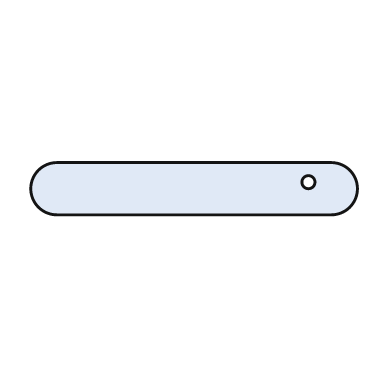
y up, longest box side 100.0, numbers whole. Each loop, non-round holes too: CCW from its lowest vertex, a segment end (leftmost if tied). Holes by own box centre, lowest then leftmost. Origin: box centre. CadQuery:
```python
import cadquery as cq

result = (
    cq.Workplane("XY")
    .moveTo(-42.0, -8.0)
    .lineTo(42.0, -8.0)
    .threePointArc((50.0, 0.0), (42.0, 8.0))
    .lineTo(-42.0, 8.0)
    .threePointArc((-50.0, 0.0), (-42.0, -8.0))
    .close()
    .moveTo(35.0, 2.0)
    .circle(2.0)
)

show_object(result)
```